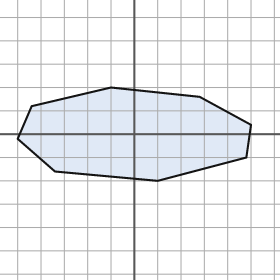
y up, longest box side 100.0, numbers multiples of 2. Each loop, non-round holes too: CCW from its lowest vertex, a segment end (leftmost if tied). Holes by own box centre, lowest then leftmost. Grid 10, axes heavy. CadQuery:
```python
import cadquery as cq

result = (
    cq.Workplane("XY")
    .moveTo(10.0, -20.0)
    .lineTo(48.0, -10.0)
    .lineTo(50.0, 4.0)
    .lineTo(28.0, 16.0)
    .lineTo(-10.0, 20.0)
    .lineTo(-44.0, 12.0)
    .lineTo(-50.0, -2.0)
    .lineTo(-34.0, -16.0)
    .close()
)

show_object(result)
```